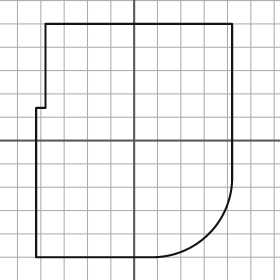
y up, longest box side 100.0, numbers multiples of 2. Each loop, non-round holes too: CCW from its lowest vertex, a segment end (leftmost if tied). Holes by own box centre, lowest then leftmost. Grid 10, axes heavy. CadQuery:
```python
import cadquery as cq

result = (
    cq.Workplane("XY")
    .moveTo(-42.0, -50.0)
    .lineTo(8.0, -50.0)
    .threePointArc((32.0, -40.0), (42.0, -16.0))
    .lineTo(42.0, 50.0)
    .lineTo(-38.0, 50.0)
    .lineTo(-38.0, 14.0)
    .lineTo(-42.0, 14.0)
    .close()
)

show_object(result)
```